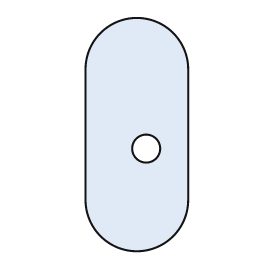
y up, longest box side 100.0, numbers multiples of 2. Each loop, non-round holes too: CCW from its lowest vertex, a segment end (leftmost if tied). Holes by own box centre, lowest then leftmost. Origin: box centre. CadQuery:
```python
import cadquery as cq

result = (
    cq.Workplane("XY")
    .moveTo(-22.0, -28.0)
    .threePointArc((0.0, -50.0), (22.0, -28.0))
    .lineTo(22.0, 28.0)
    .threePointArc((0.0, 50.0), (-22.0, 28.0))
    .close()
    .moveTo(4.0, -6.0)
    .circle(6.0)
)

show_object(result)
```